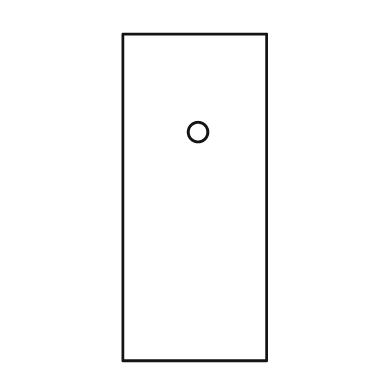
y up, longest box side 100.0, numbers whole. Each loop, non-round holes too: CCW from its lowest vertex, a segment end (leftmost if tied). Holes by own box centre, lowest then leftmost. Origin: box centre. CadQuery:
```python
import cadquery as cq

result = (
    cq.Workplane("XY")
    .moveTo(-22.0, -50.0)
    .lineTo(22.0, -50.0)
    .lineTo(22.0, 50.0)
    .lineTo(-22.0, 50.0)
    .close()
    .moveTo(1.0, 20.0)
    .circle(3.0)
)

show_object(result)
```